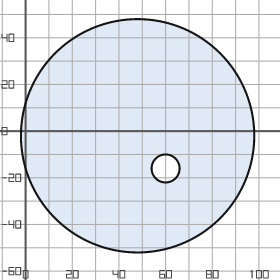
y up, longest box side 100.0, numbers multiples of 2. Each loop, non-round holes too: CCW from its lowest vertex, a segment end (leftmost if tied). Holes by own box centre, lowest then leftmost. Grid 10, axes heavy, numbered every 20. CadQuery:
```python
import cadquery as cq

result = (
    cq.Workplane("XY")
    .moveTo(48.0, -2.0)
    .circle(50.0)
    .moveTo(60.0, -16.0)
    .circle(6.0)
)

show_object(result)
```